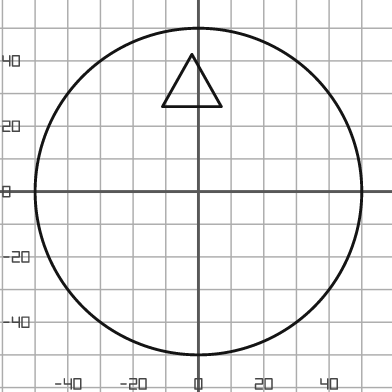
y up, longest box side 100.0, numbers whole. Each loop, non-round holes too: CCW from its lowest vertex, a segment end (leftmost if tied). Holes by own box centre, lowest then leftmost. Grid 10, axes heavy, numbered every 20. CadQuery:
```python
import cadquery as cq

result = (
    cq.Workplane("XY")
    .moveTo(0.0, 0.0)
    .circle(50.0)
    .moveTo(-11.0, 26.0)
    .lineTo(7.0, 26.0)
    .lineTo(-2.0, 42.0)
    .close()
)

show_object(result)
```